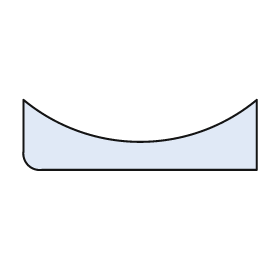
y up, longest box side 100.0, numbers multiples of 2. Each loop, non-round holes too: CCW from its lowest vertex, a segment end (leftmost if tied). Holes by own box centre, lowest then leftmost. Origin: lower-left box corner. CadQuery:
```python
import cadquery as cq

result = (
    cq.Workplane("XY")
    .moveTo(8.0, 0.0)
    .lineTo(100.0, 0.0)
    .lineTo(100.0, 30.0)
    .threePointArc((50.0, 12.0), (0.0, 30.0))
    .lineTo(0.0, 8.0)
    .threePointArc((2.0, 2.0), (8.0, 0.0))
    .close()
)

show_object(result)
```